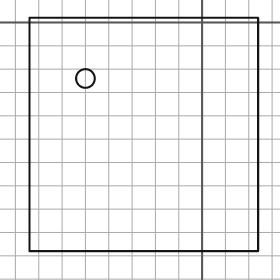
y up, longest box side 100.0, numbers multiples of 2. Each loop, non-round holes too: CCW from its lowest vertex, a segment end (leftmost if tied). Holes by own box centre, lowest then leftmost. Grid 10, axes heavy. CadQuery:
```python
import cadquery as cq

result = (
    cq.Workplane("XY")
    .moveTo(-74.0, -98.0)
    .lineTo(24.0, -98.0)
    .lineTo(24.0, 2.0)
    .lineTo(-74.0, 2.0)
    .close()
    .moveTo(-50.0, -24.0)
    .circle(4.0)
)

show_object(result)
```